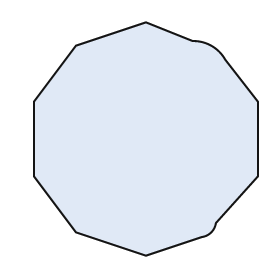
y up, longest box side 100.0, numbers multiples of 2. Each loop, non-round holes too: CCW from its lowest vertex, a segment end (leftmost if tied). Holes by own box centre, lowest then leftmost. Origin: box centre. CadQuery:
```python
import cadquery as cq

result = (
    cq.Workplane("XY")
    .moveTo(0.0, -50.0)
    .lineTo(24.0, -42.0)
    .threePointArc((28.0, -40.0), (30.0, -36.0))
    .lineTo(48.0, -16.0)
    .lineTo(48.0, 16.0)
    .lineTo(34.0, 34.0)
    .threePointArc((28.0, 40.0), (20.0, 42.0))
    .lineTo(0.0, 50.0)
    .lineTo(-30.0, 40.0)
    .lineTo(-48.0, 16.0)
    .lineTo(-48.0, -16.0)
    .lineTo(-30.0, -40.0)
    .close()
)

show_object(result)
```